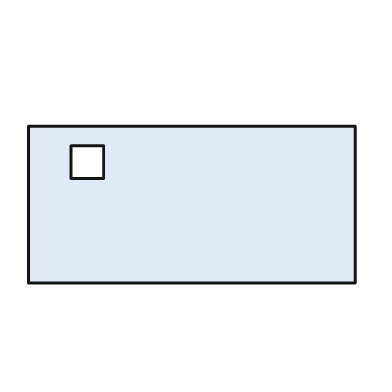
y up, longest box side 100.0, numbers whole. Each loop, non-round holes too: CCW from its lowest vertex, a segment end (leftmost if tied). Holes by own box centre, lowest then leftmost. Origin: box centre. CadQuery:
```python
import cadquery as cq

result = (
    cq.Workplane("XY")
    .moveTo(-50.0, -24.0)
    .lineTo(50.0, -24.0)
    .lineTo(50.0, 24.0)
    .lineTo(-50.0, 24.0)
    .close()
    .moveTo(-37.0, 8.0)
    .lineTo(-27.0, 8.0)
    .lineTo(-27.0, 18.0)
    .lineTo(-37.0, 18.0)
    .close()
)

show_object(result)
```